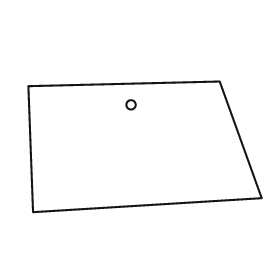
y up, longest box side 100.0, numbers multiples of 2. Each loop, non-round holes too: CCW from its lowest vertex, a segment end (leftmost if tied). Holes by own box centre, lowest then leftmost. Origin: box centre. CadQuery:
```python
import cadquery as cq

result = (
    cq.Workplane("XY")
    .moveTo(-48.0, -28.0)
    .lineTo(50.0, -22.0)
    .lineTo(32.0, 28.0)
    .lineTo(-50.0, 26.0)
    .close()
    .moveTo(-6.0, 18.0)
    .circle(2.0)
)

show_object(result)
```